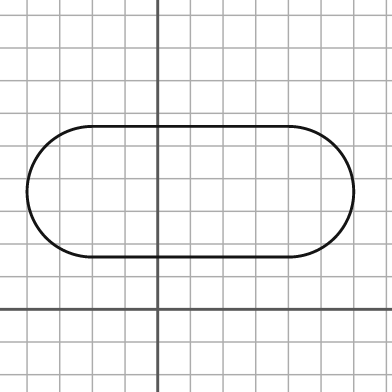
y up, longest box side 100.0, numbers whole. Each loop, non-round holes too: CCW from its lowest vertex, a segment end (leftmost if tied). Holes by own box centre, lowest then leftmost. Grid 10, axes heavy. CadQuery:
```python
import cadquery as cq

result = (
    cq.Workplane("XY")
    .moveTo(-20.0, 16.0)
    .lineTo(40.0, 16.0)
    .threePointArc((60.0, 36.0), (40.0, 56.0))
    .lineTo(-20.0, 56.0)
    .threePointArc((-40.0, 36.0), (-20.0, 16.0))
    .close()
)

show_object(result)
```